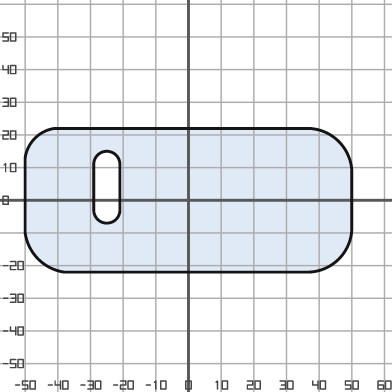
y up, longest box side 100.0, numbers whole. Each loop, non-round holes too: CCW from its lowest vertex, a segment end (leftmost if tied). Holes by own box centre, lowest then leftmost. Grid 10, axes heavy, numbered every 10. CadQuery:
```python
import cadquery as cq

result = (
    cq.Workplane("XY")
    .moveTo(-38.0, -22.0)
    .lineTo(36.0, -22.0)
    .threePointArc((46.0, -18.0), (50.0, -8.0))
    .lineTo(50.0, 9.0)
    .threePointArc((46.0, 18.0), (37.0, 22.0))
    .lineTo(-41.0, 22.0)
    .threePointArc((-47.0, 19.0), (-50.0, 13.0))
    .lineTo(-50.0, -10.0)
    .threePointArc((-46.0, -18.0), (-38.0, -22.0))
    .close()
    .moveTo(-29.0, -3.0)
    .threePointArc((-25.0, -7.0), (-21.0, -3.0))
    .lineTo(-21.0, 11.0)
    .threePointArc((-25.0, 15.0), (-29.0, 11.0))
    .close()
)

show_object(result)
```